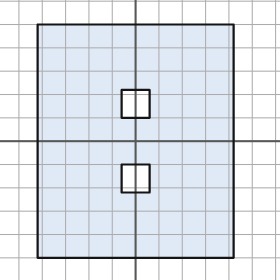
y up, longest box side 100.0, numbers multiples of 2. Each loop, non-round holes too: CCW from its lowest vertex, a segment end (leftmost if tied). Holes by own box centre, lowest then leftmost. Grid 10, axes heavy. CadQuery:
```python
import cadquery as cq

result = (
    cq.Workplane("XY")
    .moveTo(-42.0, -50.0)
    .lineTo(42.0, -50.0)
    .lineTo(42.0, 50.0)
    .lineTo(-42.0, 50.0)
    .close()
    .moveTo(-6.0, -22.0)
    .lineTo(6.0, -22.0)
    .lineTo(6.0, -10.0)
    .lineTo(-6.0, -10.0)
    .close()
    .moveTo(-6.0, 10.0)
    .lineTo(6.0, 10.0)
    .lineTo(6.0, 22.0)
    .lineTo(-6.0, 22.0)
    .close()
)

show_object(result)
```